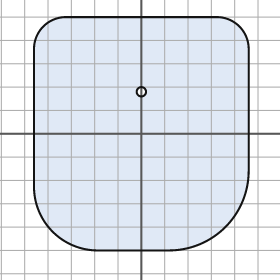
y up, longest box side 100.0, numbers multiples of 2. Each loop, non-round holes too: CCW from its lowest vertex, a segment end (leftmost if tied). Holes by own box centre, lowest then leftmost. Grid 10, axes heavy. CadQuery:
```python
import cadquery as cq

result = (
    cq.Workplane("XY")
    .moveTo(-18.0, -50.0)
    .lineTo(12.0, -50.0)
    .threePointArc((36.0, -40.0), (46.0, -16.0))
    .lineTo(46.0, 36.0)
    .threePointArc((42.0, 46.0), (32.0, 50.0))
    .lineTo(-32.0, 50.0)
    .threePointArc((-42.0, 46.0), (-46.0, 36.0))
    .lineTo(-46.0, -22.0)
    .threePointArc((-38.0, -42.0), (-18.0, -50.0))
    .close()
    .moveTo(0.0, 18.0)
    .circle(2.0)
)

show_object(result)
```